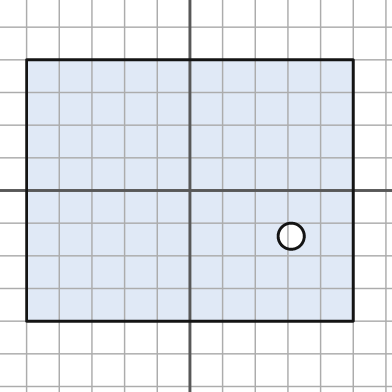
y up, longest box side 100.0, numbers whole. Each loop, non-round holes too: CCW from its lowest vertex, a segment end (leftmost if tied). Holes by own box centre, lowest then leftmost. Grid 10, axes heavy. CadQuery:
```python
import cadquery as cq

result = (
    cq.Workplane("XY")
    .moveTo(-50.0, -40.0)
    .lineTo(50.0, -40.0)
    .lineTo(50.0, 40.0)
    .lineTo(-50.0, 40.0)
    .close()
    .moveTo(31.0, -14.0)
    .circle(4.0)
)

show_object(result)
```